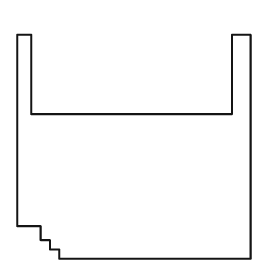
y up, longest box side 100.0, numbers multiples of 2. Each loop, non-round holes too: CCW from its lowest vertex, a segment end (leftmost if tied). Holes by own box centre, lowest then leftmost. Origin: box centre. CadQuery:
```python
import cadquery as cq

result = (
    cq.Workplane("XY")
    .moveTo(-32.0, -48.0)
    .lineTo(50.0, -48.0)
    .lineTo(50.0, 48.0)
    .lineTo(42.0, 48.0)
    .lineTo(42.0, 14.0)
    .lineTo(-44.0, 14.0)
    .lineTo(-44.0, 48.0)
    .lineTo(-50.0, 48.0)
    .lineTo(-50.0, -34.0)
    .lineTo(-40.0, -34.0)
    .lineTo(-40.0, -40.0)
    .lineTo(-36.0, -40.0)
    .lineTo(-36.0, -44.0)
    .lineTo(-32.0, -44.0)
    .close()
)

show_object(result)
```